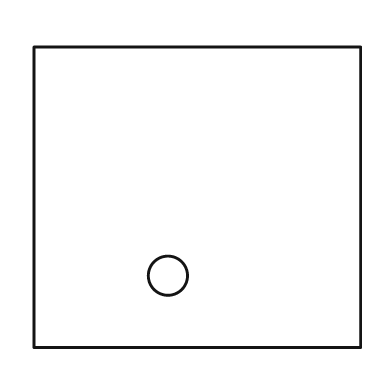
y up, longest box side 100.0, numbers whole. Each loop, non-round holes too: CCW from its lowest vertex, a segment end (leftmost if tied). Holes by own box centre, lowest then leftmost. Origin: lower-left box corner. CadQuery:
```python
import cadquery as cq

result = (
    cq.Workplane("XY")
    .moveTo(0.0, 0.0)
    .lineTo(100.0, 0.0)
    .lineTo(100.0, 92.0)
    .lineTo(0.0, 92.0)
    .close()
    .moveTo(41.0, 22.0)
    .circle(6.0)
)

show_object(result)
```